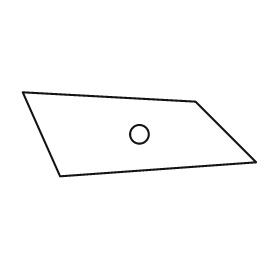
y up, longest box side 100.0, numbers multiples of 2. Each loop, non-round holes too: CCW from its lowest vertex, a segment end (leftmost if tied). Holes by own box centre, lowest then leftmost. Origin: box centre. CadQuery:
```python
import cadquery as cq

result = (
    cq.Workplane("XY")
    .moveTo(-34.0, -18.0)
    .lineTo(50.0, -12.0)
    .lineTo(24.0, 14.0)
    .lineTo(-50.0, 18.0)
    .close()
    .moveTo(0.0, 0.0)
    .circle(4.0)
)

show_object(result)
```